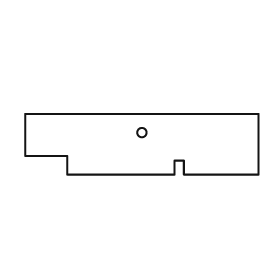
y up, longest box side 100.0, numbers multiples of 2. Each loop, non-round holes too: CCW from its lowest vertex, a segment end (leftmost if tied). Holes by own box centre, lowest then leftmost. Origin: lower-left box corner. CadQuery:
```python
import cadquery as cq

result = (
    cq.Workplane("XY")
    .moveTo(18.0, 0.0)
    .lineTo(64.0, 0.0)
    .lineTo(64.0, 6.0)
    .lineTo(68.0, 6.0)
    .lineTo(68.0, 0.0)
    .lineTo(100.0, 0.0)
    .lineTo(100.0, 26.0)
    .lineTo(0.0, 26.0)
    .lineTo(0.0, 8.0)
    .lineTo(18.0, 8.0)
    .close()
    .moveTo(50.0, 18.0)
    .circle(2.0)
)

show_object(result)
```